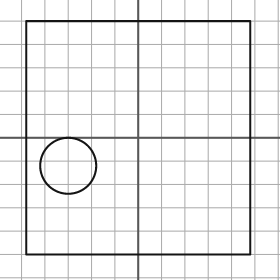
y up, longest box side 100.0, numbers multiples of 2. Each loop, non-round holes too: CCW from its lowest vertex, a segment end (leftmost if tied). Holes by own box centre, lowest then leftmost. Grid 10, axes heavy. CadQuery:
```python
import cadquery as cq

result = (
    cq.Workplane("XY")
    .moveTo(-48.0, -50.0)
    .lineTo(48.0, -50.0)
    .lineTo(48.0, 50.0)
    .lineTo(-48.0, 50.0)
    .close()
    .moveTo(-30.0, -12.0)
    .circle(12.0)
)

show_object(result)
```